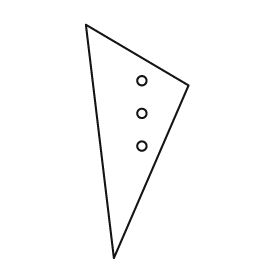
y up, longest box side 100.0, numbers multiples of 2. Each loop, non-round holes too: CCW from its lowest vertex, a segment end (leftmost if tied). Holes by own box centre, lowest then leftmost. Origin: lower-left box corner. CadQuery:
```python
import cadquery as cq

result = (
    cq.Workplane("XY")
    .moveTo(12.0, 0.0)
    .lineTo(44.0, 74.0)
    .lineTo(0.0, 100.0)
    .close()
    .moveTo(24.0, 48.0)
    .circle(2.0)
    .moveTo(24.0, 62.0)
    .circle(2.0)
    .moveTo(24.0, 76.0)
    .circle(2.0)
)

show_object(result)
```